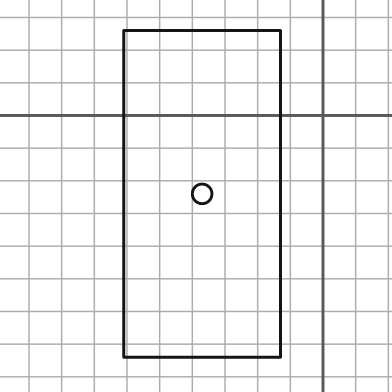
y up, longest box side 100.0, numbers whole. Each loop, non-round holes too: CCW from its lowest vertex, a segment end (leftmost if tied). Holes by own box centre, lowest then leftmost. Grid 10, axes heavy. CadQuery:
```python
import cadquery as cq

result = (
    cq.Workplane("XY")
    .moveTo(-61.0, -74.0)
    .lineTo(-13.0, -74.0)
    .lineTo(-13.0, 26.0)
    .lineTo(-61.0, 26.0)
    .close()
    .moveTo(-37.0, -24.0)
    .circle(3.0)
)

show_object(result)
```